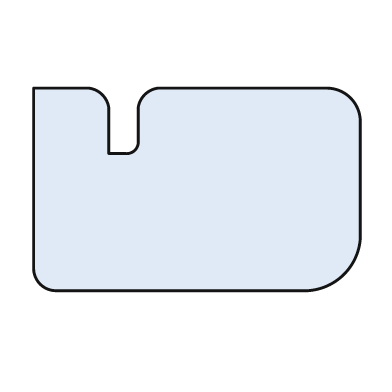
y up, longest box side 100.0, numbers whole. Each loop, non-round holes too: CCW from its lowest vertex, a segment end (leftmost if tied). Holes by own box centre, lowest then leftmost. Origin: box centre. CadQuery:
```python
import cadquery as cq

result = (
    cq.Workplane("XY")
    .moveTo(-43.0, -31.0)
    .lineTo(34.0, -31.0)
    .threePointArc((45.0, -26.0), (50.0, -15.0))
    .lineTo(50.0, 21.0)
    .threePointArc((47.0, 28.0), (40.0, 31.0))
    .lineTo(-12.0, 31.0)
    .threePointArc((-16.0, 29.0), (-18.0, 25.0))
    .lineTo(-18.0, 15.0)
    .threePointArc((-19.0, 12.0), (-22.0, 11.0))
    .lineTo(-27.0, 11.0)
    .lineTo(-27.0, 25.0)
    .threePointArc((-29.0, 29.0), (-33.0, 31.0))
    .lineTo(-50.0, 31.0)
    .lineTo(-50.0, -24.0)
    .threePointArc((-48.0, -29.0), (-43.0, -31.0))
    .close()
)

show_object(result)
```